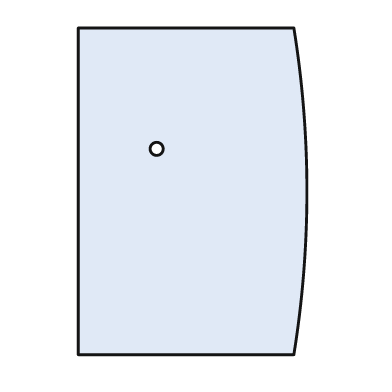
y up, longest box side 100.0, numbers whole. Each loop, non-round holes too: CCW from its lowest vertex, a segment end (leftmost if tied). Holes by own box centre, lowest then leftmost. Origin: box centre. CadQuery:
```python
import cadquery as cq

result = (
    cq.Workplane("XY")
    .moveTo(-35.0, -50.0)
    .lineTo(31.0, -50.0)
    .threePointArc((35.0, 0.0), (31.0, 50.0))
    .lineTo(-35.0, 50.0)
    .close()
    .moveTo(-11.0, 13.0)
    .circle(2.0)
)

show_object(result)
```